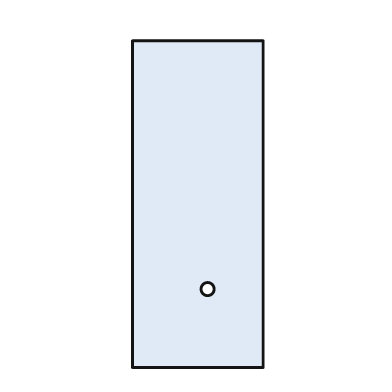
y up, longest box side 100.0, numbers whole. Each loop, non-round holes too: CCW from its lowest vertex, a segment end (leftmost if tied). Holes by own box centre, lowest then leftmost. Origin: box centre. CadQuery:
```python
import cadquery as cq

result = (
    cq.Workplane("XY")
    .moveTo(-20.0, -50.0)
    .lineTo(20.0, -50.0)
    .lineTo(20.0, 50.0)
    .lineTo(-20.0, 50.0)
    .close()
    .moveTo(3.0, -26.0)
    .circle(2.0)
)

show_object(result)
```